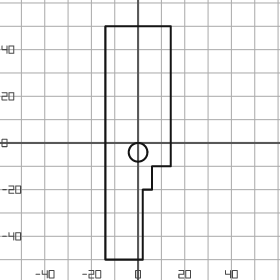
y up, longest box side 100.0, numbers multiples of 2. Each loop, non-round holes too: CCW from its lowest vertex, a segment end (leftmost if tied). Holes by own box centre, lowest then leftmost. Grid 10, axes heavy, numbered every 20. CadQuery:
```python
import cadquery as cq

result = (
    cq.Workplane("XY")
    .moveTo(-14.0, -50.0)
    .lineTo(2.0, -50.0)
    .lineTo(2.0, -20.0)
    .lineTo(6.0, -20.0)
    .lineTo(6.0, -10.0)
    .lineTo(14.0, -10.0)
    .lineTo(14.0, 50.0)
    .lineTo(-14.0, 50.0)
    .close()
    .moveTo(0.0, -4.0)
    .circle(4.0)
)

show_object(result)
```